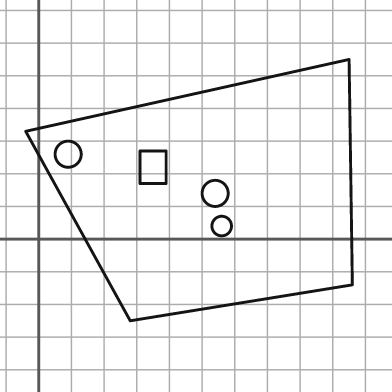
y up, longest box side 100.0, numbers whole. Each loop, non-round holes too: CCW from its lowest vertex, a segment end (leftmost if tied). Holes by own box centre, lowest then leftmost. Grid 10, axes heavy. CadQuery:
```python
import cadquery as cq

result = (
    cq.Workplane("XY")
    .moveTo(28.0, -25.0)
    .lineTo(96.0, -14.0)
    .lineTo(95.0, 55.0)
    .lineTo(-4.0, 33.0)
    .close()
    .moveTo(56.0, 4.0)
    .circle(3.0)
    .moveTo(54.0, 14.0)
    .circle(4.0)
    .moveTo(31.0, 17.0)
    .lineTo(39.0, 17.0)
    .lineTo(39.0, 27.0)
    .lineTo(31.0, 27.0)
    .close()
    .moveTo(9.0, 26.0)
    .circle(4.0)
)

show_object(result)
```